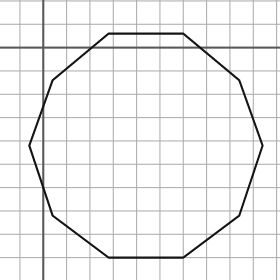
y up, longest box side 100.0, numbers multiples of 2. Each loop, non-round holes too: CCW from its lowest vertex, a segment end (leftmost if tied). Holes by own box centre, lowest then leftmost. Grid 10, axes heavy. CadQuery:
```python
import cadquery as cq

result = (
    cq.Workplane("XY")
    .moveTo(28.0, -90.0)
    .lineTo(60.0, -90.0)
    .lineTo(84.0, -72.0)
    .lineTo(94.0, -42.0)
    .lineTo(84.0, -14.0)
    .lineTo(60.0, 6.0)
    .lineTo(28.0, 6.0)
    .lineTo(4.0, -14.0)
    .lineTo(-6.0, -42.0)
    .lineTo(4.0, -72.0)
    .close()
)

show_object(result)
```